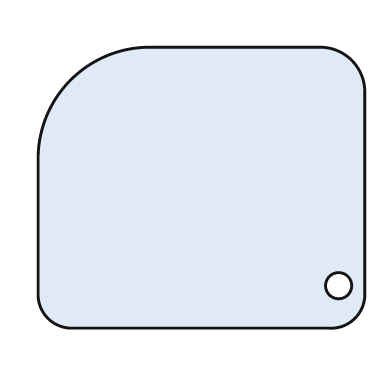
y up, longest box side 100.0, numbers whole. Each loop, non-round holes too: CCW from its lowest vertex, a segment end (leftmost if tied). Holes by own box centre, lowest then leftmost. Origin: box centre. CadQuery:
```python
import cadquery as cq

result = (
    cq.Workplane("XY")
    .moveTo(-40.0, -43.0)
    .lineTo(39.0, -43.0)
    .threePointArc((47.0, -40.0), (50.0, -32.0))
    .lineTo(50.0, 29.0)
    .threePointArc((46.0, 39.0), (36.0, 43.0))
    .lineTo(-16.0, 43.0)
    .threePointArc((-40.0, 33.0), (-50.0, 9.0))
    .lineTo(-50.0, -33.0)
    .threePointArc((-47.0, -40.0), (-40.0, -43.0))
    .close()
    .moveTo(42.0, -30.0)
    .circle(4.0)
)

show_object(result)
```